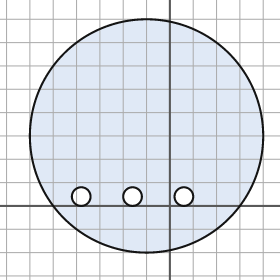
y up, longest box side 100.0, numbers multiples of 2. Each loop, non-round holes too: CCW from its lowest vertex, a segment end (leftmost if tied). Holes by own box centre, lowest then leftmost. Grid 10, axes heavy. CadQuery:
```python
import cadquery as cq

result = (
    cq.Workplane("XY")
    .moveTo(-10.0, 30.0)
    .circle(50.0)
    .moveTo(-38.0, 4.0)
    .circle(4.0)
    .moveTo(-16.0, 4.0)
    .circle(4.0)
    .moveTo(6.0, 4.0)
    .circle(4.0)
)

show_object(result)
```